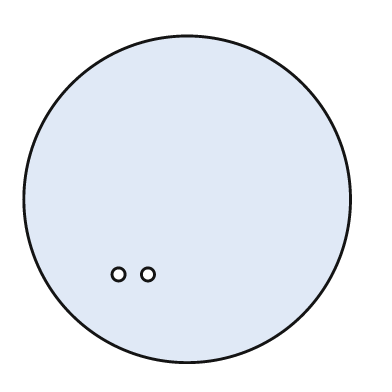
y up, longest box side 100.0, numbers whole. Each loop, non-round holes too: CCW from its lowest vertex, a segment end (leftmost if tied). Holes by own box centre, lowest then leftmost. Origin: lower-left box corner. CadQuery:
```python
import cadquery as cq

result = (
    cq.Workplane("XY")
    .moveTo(50.0, 50.0)
    .circle(50.0)
    .moveTo(29.0, 27.0)
    .circle(2.0)
    .moveTo(38.0, 27.0)
    .circle(2.0)
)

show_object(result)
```